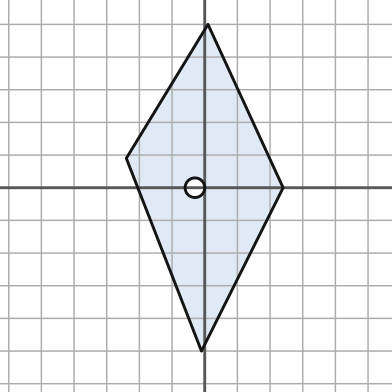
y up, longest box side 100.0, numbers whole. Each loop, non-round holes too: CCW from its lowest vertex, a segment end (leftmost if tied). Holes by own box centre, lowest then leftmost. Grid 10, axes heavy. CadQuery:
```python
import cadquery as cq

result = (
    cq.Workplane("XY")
    .moveTo(-1.0, -50.0)
    .lineTo(24.0, 0.0)
    .lineTo(1.0, 50.0)
    .lineTo(-24.0, 9.0)
    .close()
    .moveTo(-3.0, 0.0)
    .circle(3.0)
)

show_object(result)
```